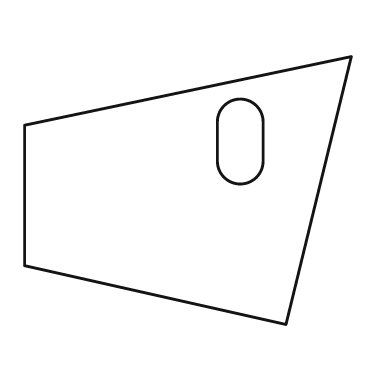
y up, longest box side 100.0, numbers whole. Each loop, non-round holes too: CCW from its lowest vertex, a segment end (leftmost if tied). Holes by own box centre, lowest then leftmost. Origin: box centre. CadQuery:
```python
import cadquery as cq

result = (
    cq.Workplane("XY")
    .moveTo(30.0, -41.0)
    .lineTo(50.0, 41.0)
    .lineTo(-50.0, 20.0)
    .lineTo(-50.0, -23.0)
    .close()
    .moveTo(9.0, 9.0)
    .threePointArc((16.0, 2.0), (23.0, 9.0))
    .lineTo(23.0, 21.0)
    .threePointArc((16.0, 28.0), (9.0, 21.0))
    .close()
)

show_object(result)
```